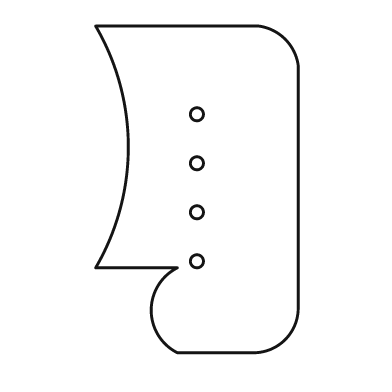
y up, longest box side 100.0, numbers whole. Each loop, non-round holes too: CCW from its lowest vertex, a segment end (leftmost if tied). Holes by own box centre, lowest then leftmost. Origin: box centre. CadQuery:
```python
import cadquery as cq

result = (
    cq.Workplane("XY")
    .moveTo(-6.0, -50.0)
    .lineTo(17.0, -50.0)
    .threePointArc((27.0, -46.0), (31.0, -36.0))
    .lineTo(31.0, 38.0)
    .threePointArc((27.0, 46.0), (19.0, 50.0))
    .lineTo(-31.0, 50.0)
    .threePointArc((-21.0, 13.0), (-31.0, -24.0))
    .lineTo(-6.0, -24.0)
    .threePointArc((-14.0, -37.0), (-6.0, -50.0))
    .close()
    .moveTo(0.0, -22.0)
    .circle(2.0)
    .moveTo(0.0, -7.0)
    .circle(2.0)
    .moveTo(0.0, 8.0)
    .circle(2.0)
    .moveTo(0.0, 23.0)
    .circle(2.0)
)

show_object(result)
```